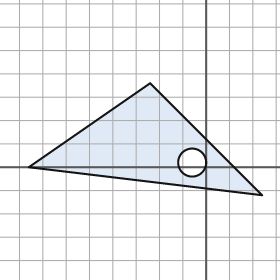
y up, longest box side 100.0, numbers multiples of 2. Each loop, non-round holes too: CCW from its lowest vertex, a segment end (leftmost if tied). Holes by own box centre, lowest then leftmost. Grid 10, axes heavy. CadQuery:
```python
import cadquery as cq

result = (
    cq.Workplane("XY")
    .moveTo(24.0, -12.0)
    .lineTo(-24.0, 36.0)
    .lineTo(-76.0, 0.0)
    .close()
    .moveTo(-6.0, 2.0)
    .circle(6.0)
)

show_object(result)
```